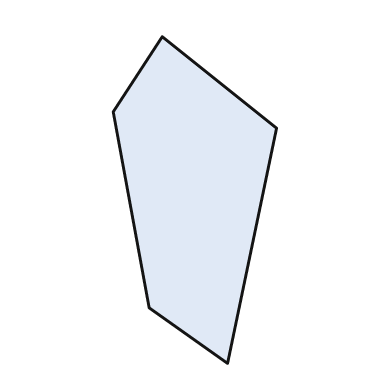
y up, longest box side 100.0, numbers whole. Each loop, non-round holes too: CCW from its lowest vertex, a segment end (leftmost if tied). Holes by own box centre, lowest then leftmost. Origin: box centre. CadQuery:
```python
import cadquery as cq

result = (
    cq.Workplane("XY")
    .moveTo(10.0, -50.0)
    .lineTo(25.0, 22.0)
    .lineTo(-10.0, 50.0)
    .lineTo(-25.0, 27.0)
    .lineTo(-14.0, -33.0)
    .close()
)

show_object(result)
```